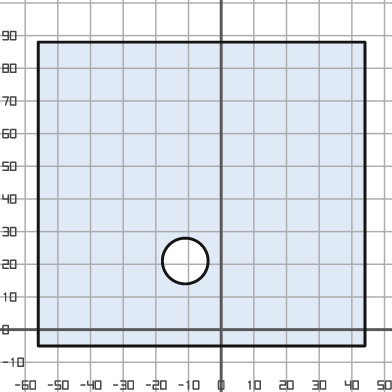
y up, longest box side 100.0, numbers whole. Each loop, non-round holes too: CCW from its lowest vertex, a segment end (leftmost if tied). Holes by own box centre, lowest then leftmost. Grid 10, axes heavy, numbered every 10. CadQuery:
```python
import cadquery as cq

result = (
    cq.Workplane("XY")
    .moveTo(-56.0, -5.0)
    .lineTo(44.0, -5.0)
    .lineTo(44.0, 88.0)
    .lineTo(-56.0, 88.0)
    .close()
    .moveTo(-11.0, 21.0)
    .circle(7.0)
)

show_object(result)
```